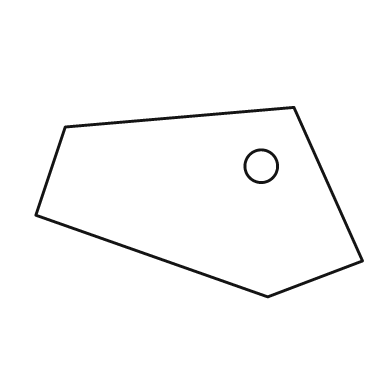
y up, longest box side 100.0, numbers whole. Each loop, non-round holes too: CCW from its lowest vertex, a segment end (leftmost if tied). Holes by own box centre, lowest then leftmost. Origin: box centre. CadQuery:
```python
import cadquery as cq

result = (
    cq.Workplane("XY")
    .moveTo(21.0, -29.0)
    .lineTo(50.0, -18.0)
    .lineTo(29.0, 29.0)
    .lineTo(-41.0, 23.0)
    .lineTo(-50.0, -4.0)
    .close()
    .moveTo(19.0, 11.0)
    .circle(5.0)
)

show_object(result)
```